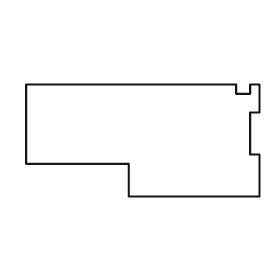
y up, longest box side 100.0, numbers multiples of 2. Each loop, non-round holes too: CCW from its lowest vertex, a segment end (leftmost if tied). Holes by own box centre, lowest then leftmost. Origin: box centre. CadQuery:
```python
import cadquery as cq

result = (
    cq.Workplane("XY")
    .moveTo(-6.0, -24.0)
    .lineTo(50.0, -24.0)
    .lineTo(50.0, -6.0)
    .lineTo(46.0, -6.0)
    .lineTo(46.0, 12.0)
    .lineTo(50.0, 12.0)
    .lineTo(50.0, 24.0)
    .lineTo(46.0, 24.0)
    .lineTo(46.0, 20.0)
    .lineTo(40.0, 20.0)
    .lineTo(40.0, 24.0)
    .lineTo(-50.0, 24.0)
    .lineTo(-50.0, -10.0)
    .lineTo(-6.0, -10.0)
    .close()
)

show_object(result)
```